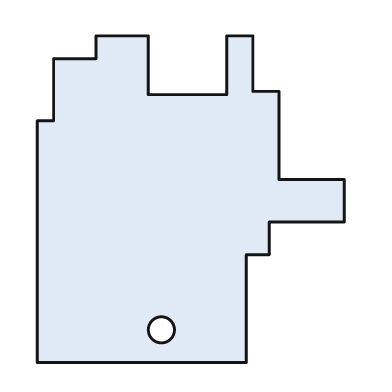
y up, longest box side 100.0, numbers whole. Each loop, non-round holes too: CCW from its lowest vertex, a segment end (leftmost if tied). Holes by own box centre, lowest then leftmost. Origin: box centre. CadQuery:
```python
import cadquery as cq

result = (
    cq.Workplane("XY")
    .moveTo(-47.0, -50.0)
    .lineTo(17.0, -50.0)
    .lineTo(17.0, -17.0)
    .lineTo(24.0, -17.0)
    .lineTo(24.0, -7.0)
    .lineTo(47.0, -7.0)
    .lineTo(47.0, 6.0)
    .lineTo(27.0, 6.0)
    .lineTo(27.0, 33.0)
    .lineTo(19.0, 33.0)
    .lineTo(19.0, 50.0)
    .lineTo(11.0, 50.0)
    .lineTo(11.0, 32.0)
    .lineTo(-13.0, 32.0)
    .lineTo(-13.0, 50.0)
    .lineTo(-29.0, 50.0)
    .lineTo(-29.0, 43.0)
    .lineTo(-42.0, 43.0)
    .lineTo(-42.0, 24.0)
    .lineTo(-47.0, 24.0)
    .close()
    .moveTo(-9.0, -40.0)
    .circle(4.0)
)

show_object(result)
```